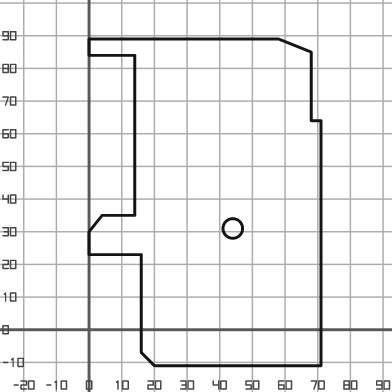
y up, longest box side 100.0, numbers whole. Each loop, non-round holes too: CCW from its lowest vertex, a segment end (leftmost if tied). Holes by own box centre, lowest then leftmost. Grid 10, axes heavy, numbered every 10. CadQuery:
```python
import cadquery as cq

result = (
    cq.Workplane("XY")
    .moveTo(20.0, -11.0)
    .lineTo(71.0, -11.0)
    .lineTo(71.0, 64.0)
    .lineTo(68.0, 64.0)
    .lineTo(68.0, 85.0)
    .lineTo(58.0, 89.0)
    .lineTo(0.0, 89.0)
    .lineTo(0.0, 84.0)
    .lineTo(14.0, 84.0)
    .lineTo(14.0, 35.0)
    .lineTo(4.0, 35.0)
    .lineTo(0.0, 30.0)
    .lineTo(0.0, 23.0)
    .lineTo(16.0, 23.0)
    .lineTo(16.0, -7.0)
    .close()
    .moveTo(44.0, 31.0)
    .circle(3.0)
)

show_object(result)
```